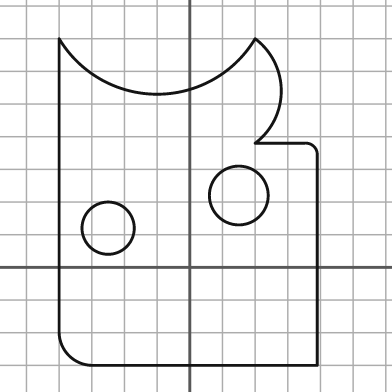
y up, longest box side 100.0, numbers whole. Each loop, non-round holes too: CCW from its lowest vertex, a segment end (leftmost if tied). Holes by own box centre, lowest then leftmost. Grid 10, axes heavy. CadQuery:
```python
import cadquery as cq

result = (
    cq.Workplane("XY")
    .moveTo(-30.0, -30.0)
    .lineTo(39.0, -30.0)
    .lineTo(39.0, 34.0)
    .threePointArc((38.0, 37.0), (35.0, 38.0))
    .lineTo(20.0, 38.0)
    .threePointArc((28.0, 54.0), (20.0, 70.0))
    .threePointArc((-10.0, 53.0), (-40.0, 70.0))
    .lineTo(-40.0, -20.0)
    .threePointArc((-37.0, -27.0), (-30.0, -30.0))
    .close()
    .moveTo(-25.0, 12.0)
    .circle(8.0)
    .moveTo(15.0, 22.0)
    .circle(9.0)
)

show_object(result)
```